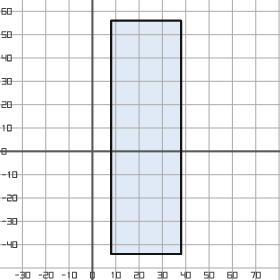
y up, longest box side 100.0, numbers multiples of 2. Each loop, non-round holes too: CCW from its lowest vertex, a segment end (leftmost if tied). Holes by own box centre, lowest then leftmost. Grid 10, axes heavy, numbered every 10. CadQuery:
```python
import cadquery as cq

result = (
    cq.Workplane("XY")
    .moveTo(8.0, -44.0)
    .lineTo(38.0, -44.0)
    .lineTo(38.0, 56.0)
    .lineTo(8.0, 56.0)
    .close()
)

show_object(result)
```